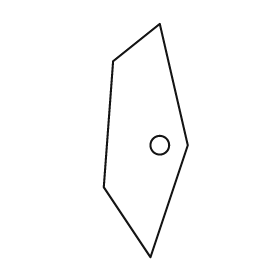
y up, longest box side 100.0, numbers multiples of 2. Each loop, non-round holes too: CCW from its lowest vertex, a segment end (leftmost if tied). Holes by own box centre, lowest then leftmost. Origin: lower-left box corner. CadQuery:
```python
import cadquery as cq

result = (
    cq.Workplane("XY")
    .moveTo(20.0, 0.0)
    .lineTo(36.0, 48.0)
    .lineTo(24.0, 100.0)
    .lineTo(4.0, 84.0)
    .lineTo(0.0, 30.0)
    .close()
    .moveTo(24.0, 48.0)
    .circle(4.0)
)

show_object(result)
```